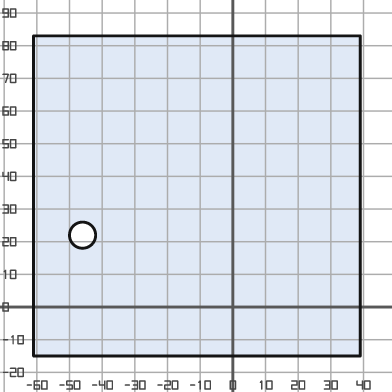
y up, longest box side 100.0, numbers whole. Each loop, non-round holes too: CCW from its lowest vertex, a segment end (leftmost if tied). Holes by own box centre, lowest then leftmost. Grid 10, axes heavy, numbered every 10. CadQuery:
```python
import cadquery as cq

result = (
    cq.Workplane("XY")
    .moveTo(-61.0, -15.0)
    .lineTo(39.0, -15.0)
    .lineTo(39.0, 83.0)
    .lineTo(-61.0, 83.0)
    .close()
    .moveTo(-46.0, 22.0)
    .circle(4.0)
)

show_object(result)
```